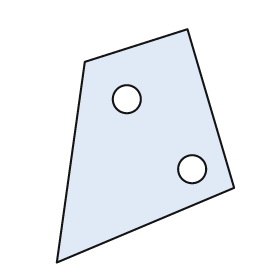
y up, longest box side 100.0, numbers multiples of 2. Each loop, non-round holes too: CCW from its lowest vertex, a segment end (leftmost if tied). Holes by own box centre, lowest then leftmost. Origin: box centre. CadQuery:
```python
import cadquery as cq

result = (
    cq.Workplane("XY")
    .moveTo(-38.0, -50.0)
    .lineTo(38.0, -18.0)
    .lineTo(18.0, 50.0)
    .lineTo(-26.0, 36.0)
    .close()
    .moveTo(20.0, -10.0)
    .circle(6.0)
    .moveTo(-8.0, 20.0)
    .circle(6.0)
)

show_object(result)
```